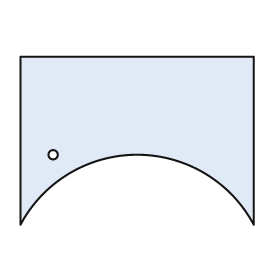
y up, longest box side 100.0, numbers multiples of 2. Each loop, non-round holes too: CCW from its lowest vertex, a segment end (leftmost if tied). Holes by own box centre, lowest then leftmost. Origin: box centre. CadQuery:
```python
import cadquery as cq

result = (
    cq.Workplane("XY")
    .moveTo(-50.0, -36.0)
    .threePointArc((0.0, -6.0), (50.0, -36.0))
    .lineTo(50.0, 36.0)
    .lineTo(-50.0, 36.0)
    .close()
    .moveTo(-36.0, -6.0)
    .circle(2.0)
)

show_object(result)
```